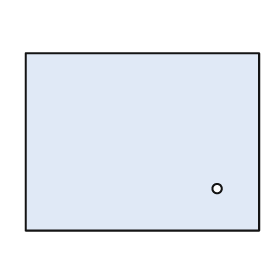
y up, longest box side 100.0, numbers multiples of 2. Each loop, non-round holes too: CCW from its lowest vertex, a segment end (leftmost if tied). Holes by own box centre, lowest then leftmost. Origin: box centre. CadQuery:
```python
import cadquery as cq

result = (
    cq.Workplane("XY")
    .moveTo(-50.0, -38.0)
    .lineTo(50.0, -38.0)
    .lineTo(50.0, 38.0)
    .lineTo(-50.0, 38.0)
    .close()
    .moveTo(32.0, -20.0)
    .circle(2.0)
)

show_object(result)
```